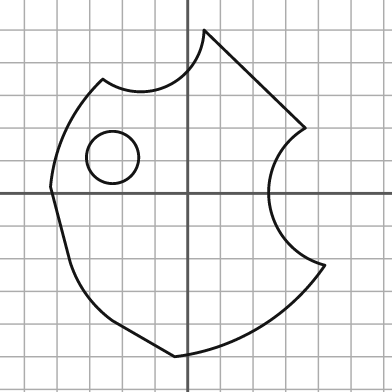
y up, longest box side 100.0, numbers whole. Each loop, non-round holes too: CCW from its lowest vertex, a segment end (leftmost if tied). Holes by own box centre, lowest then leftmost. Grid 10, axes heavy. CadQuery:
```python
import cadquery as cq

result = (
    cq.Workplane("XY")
    .moveTo(-4.0, -50.0)
    .threePointArc((22.0, -41.0), (42.0, -22.0))
    .threePointArc((25.0, -3.0), (36.0, 20.0))
    .lineTo(5.0, 50.0)
    .threePointArc((-6.0, 33.0), (-26.0, 35.0))
    .threePointArc((-37.0, 20.0), (-42.0, 2.0))
    .lineTo(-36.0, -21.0)
    .threePointArc((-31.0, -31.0), (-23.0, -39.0))
    .close()
    .moveTo(-23.0, 11.0)
    .circle(8.0)
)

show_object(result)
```